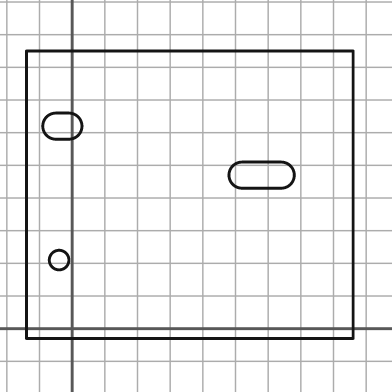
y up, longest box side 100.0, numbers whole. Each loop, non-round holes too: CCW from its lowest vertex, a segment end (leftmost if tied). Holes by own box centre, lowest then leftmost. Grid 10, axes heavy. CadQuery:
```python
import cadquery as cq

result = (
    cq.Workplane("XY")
    .moveTo(-14.0, -3.0)
    .lineTo(86.0, -3.0)
    .lineTo(86.0, 85.0)
    .lineTo(-14.0, 85.0)
    .close()
    .moveTo(-4.0, 21.0)
    .circle(3.0)
    .moveTo(52.0, 43.0)
    .lineTo(64.0, 43.0)
    .threePointArc((68.0, 47.0), (64.0, 51.0))
    .lineTo(52.0, 51.0)
    .threePointArc((48.0, 47.0), (52.0, 43.0))
    .close()
    .moveTo(-5.0, 58.0)
    .lineTo(-1.0, 58.0)
    .threePointArc((3.0, 62.0), (-1.0, 66.0))
    .lineTo(-5.0, 66.0)
    .threePointArc((-9.0, 62.0), (-5.0, 58.0))
    .close()
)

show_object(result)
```